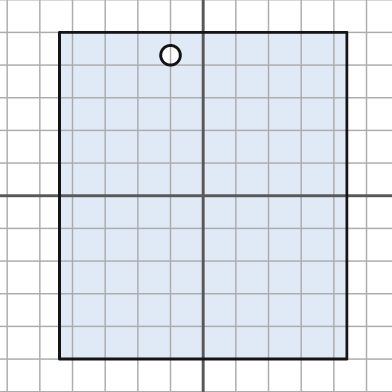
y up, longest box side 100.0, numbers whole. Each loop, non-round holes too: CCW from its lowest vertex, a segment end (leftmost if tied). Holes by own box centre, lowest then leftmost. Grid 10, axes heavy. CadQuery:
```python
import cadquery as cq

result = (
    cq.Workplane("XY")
    .moveTo(-44.0, -50.0)
    .lineTo(44.0, -50.0)
    .lineTo(44.0, 50.0)
    .lineTo(-44.0, 50.0)
    .close()
    .moveTo(-10.0, 43.0)
    .circle(3.0)
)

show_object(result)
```